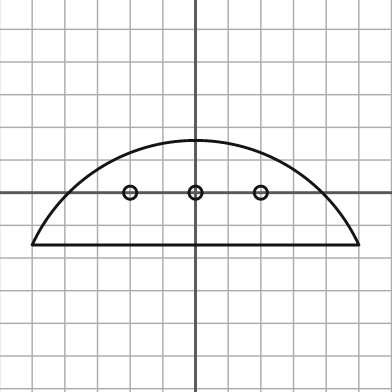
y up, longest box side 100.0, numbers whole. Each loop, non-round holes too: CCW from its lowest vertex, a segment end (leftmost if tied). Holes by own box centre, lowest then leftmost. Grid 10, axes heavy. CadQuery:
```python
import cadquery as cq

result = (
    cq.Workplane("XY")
    .moveTo(-50.0, -16.0)
    .lineTo(50.0, -16.0)
    .threePointArc((0.0, 16.0), (-50.0, -16.0))
    .close()
    .moveTo(-20.0, 0.0)
    .circle(2.0)
    .moveTo(0.0, 0.0)
    .circle(2.0)
    .moveTo(20.0, 0.0)
    .circle(2.0)
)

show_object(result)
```